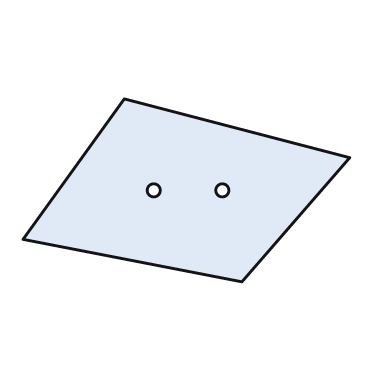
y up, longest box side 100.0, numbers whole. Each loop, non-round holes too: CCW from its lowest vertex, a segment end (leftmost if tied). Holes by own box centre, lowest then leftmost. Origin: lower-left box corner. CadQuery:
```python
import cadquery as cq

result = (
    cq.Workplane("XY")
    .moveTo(67.0, 0.0)
    .lineTo(100.0, 38.0)
    .lineTo(31.0, 56.0)
    .lineTo(0.0, 13.0)
    .close()
    .moveTo(40.0, 28.0)
    .circle(2.0)
    .moveTo(61.0, 28.0)
    .circle(2.0)
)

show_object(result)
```